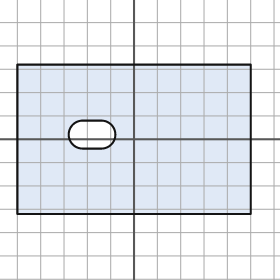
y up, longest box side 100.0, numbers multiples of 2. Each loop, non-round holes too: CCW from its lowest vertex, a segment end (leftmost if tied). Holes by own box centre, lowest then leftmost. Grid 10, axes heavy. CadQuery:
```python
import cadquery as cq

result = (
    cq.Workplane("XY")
    .moveTo(-50.0, -32.0)
    .lineTo(50.0, -32.0)
    .lineTo(50.0, 32.0)
    .lineTo(-50.0, 32.0)
    .close()
    .moveTo(-22.0, -4.0)
    .lineTo(-14.0, -4.0)
    .threePointArc((-8.0, 2.0), (-14.0, 8.0))
    .lineTo(-22.0, 8.0)
    .threePointArc((-28.0, 2.0), (-22.0, -4.0))
    .close()
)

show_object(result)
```